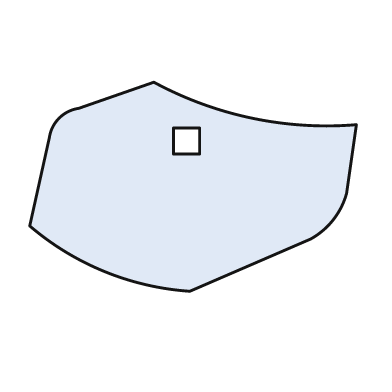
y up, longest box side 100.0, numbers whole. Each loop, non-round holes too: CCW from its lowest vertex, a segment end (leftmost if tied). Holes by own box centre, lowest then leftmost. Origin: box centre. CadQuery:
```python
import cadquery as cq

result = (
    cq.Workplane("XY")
    .moveTo(-1.0, -32.0)
    .lineTo(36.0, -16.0)
    .threePointArc((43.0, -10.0), (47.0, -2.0))
    .lineTo(50.0, 19.0)
    .threePointArc((18.0, 21.0), (-12.0, 32.0))
    .lineTo(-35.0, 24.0)
    .threePointArc((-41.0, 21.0), (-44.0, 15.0))
    .lineTo(-50.0, -12.0)
    .threePointArc((-27.0, -26.0), (-1.0, -32.0))
    .close()
    .moveTo(-6.0, 10.0)
    .lineTo(2.0, 10.0)
    .lineTo(2.0, 18.0)
    .lineTo(-6.0, 18.0)
    .close()
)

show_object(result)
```